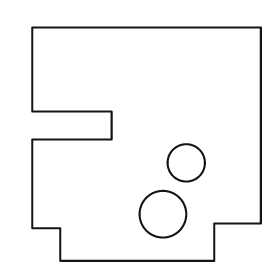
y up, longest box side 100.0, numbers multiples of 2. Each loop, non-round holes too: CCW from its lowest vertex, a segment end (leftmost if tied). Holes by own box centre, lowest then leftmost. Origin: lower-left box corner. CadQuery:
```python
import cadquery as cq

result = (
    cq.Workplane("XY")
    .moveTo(12.0, 0.0)
    .lineTo(78.0, 0.0)
    .lineTo(78.0, 16.0)
    .lineTo(98.0, 16.0)
    .lineTo(98.0, 100.0)
    .lineTo(0.0, 100.0)
    .lineTo(0.0, 64.0)
    .lineTo(34.0, 64.0)
    .lineTo(34.0, 52.0)
    .lineTo(0.0, 52.0)
    .lineTo(0.0, 14.0)
    .lineTo(12.0, 14.0)
    .close()
    .moveTo(56.0, 20.0)
    .circle(10.0)
    .moveTo(66.0, 42.0)
    .circle(8.0)
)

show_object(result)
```